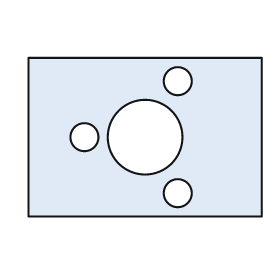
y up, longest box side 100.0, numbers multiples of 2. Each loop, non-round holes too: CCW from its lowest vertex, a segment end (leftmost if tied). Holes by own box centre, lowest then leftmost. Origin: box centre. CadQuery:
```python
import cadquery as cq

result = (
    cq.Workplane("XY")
    .moveTo(-50.0, -34.0)
    .lineTo(50.0, -34.0)
    .lineTo(50.0, 34.0)
    .lineTo(-50.0, 34.0)
    .close()
    .moveTo(14.0, -24.0)
    .circle(6.0)
    .moveTo(-26.0, 0.0)
    .circle(6.0)
    .moveTo(0.0, 0.0)
    .circle(16.0)
    .moveTo(14.0, 24.0)
    .circle(6.0)
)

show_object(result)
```